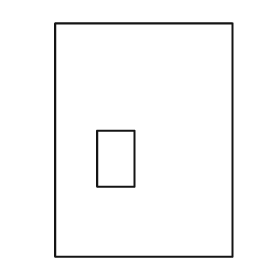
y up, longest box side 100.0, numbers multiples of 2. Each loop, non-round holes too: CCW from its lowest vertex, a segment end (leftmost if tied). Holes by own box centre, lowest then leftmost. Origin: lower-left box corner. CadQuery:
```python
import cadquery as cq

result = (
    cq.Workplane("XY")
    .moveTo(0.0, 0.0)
    .lineTo(76.0, 0.0)
    .lineTo(76.0, 100.0)
    .lineTo(0.0, 100.0)
    .close()
    .moveTo(18.0, 30.0)
    .lineTo(34.0, 30.0)
    .lineTo(34.0, 54.0)
    .lineTo(18.0, 54.0)
    .close()
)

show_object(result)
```